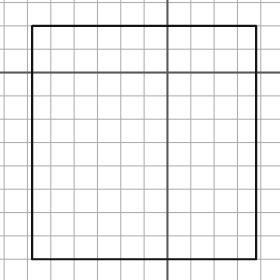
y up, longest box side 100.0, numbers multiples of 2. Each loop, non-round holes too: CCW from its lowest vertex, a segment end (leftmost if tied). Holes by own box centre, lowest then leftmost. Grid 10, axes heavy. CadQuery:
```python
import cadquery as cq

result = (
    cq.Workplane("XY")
    .moveTo(-58.0, -80.0)
    .lineTo(38.0, -80.0)
    .lineTo(38.0, 20.0)
    .lineTo(-58.0, 20.0)
    .close()
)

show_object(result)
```